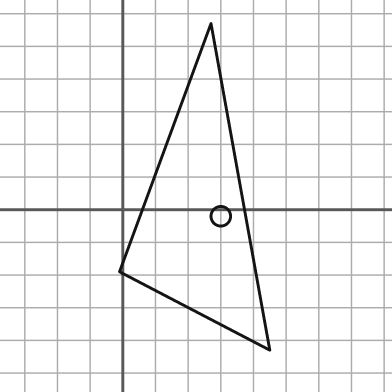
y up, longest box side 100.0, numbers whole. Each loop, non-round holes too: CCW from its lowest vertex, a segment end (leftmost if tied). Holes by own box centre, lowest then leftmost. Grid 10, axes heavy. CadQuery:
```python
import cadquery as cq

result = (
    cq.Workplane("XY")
    .moveTo(45.0, -43.0)
    .lineTo(27.0, 57.0)
    .lineTo(-1.0, -19.0)
    .close()
    .moveTo(30.0, -2.0)
    .circle(3.0)
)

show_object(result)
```